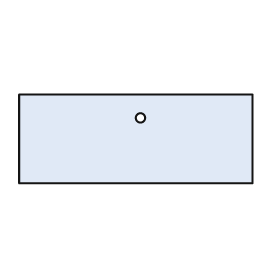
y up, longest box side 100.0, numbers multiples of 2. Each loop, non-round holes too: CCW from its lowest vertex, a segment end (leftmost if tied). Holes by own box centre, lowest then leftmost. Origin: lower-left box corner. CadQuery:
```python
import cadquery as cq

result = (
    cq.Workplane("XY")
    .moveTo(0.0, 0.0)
    .lineTo(100.0, 0.0)
    .lineTo(100.0, 38.0)
    .lineTo(0.0, 38.0)
    .close()
    .moveTo(52.0, 28.0)
    .circle(2.0)
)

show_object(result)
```